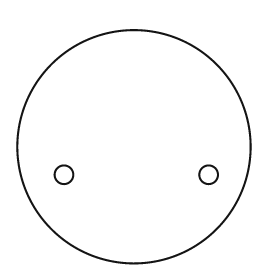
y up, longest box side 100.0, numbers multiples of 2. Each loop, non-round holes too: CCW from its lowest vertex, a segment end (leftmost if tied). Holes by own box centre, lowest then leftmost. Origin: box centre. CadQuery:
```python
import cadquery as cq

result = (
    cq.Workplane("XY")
    .moveTo(0.0, 0.0)
    .circle(50.0)
    .moveTo(-30.0, -12.0)
    .circle(4.0)
    .moveTo(32.0, -12.0)
    .circle(4.0)
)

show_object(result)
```